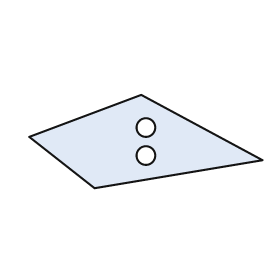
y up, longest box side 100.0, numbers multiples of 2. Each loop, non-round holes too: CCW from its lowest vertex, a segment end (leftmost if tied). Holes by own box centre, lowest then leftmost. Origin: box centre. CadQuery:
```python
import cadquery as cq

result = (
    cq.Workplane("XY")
    .moveTo(-22.0, -20.0)
    .lineTo(50.0, -8.0)
    .lineTo(-2.0, 20.0)
    .lineTo(-50.0, 2.0)
    .close()
    .moveTo(0.0, -6.0)
    .circle(4.0)
    .moveTo(0.0, 6.0)
    .circle(4.0)
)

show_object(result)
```